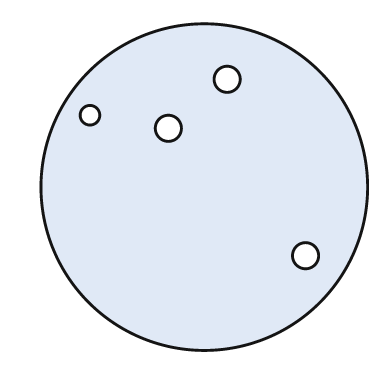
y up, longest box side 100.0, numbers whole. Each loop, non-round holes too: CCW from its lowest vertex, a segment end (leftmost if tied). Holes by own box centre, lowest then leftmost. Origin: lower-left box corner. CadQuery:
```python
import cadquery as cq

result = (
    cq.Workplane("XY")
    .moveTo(50.0, 50.0)
    .circle(50.0)
    .moveTo(81.0, 29.0)
    .circle(4.0)
    .moveTo(39.0, 68.0)
    .circle(4.0)
    .moveTo(15.0, 72.0)
    .circle(3.0)
    .moveTo(57.0, 83.0)
    .circle(4.0)
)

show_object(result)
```